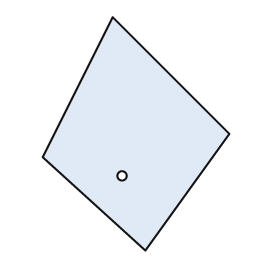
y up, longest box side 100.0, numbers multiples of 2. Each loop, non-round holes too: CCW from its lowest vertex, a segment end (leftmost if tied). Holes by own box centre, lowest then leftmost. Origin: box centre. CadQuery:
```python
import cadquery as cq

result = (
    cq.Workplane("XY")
    .moveTo(4.0, -50.0)
    .lineTo(40.0, 0.0)
    .lineTo(-10.0, 50.0)
    .lineTo(-40.0, -10.0)
    .close()
    .moveTo(-6.0, -18.0)
    .circle(2.0)
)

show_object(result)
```